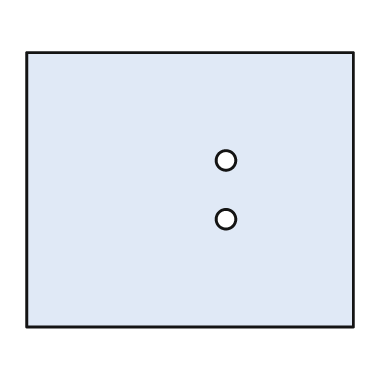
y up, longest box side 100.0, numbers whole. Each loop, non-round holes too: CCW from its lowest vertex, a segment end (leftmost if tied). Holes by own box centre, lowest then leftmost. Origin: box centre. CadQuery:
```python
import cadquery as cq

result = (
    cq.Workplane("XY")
    .moveTo(-50.0, -42.0)
    .lineTo(50.0, -42.0)
    .lineTo(50.0, 42.0)
    .lineTo(-50.0, 42.0)
    .close()
    .moveTo(11.0, -9.0)
    .circle(3.0)
    .moveTo(11.0, 9.0)
    .circle(3.0)
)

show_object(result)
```